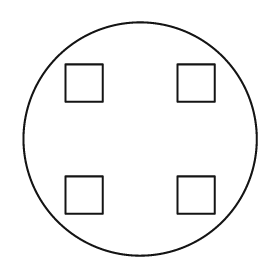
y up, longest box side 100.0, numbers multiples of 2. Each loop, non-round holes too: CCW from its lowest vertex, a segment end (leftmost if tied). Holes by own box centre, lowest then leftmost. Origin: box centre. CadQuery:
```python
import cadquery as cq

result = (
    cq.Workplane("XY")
    .moveTo(0.0, 0.0)
    .circle(50.0)
    .moveTo(-32.0, -32.0)
    .lineTo(-16.0, -32.0)
    .lineTo(-16.0, -16.0)
    .lineTo(-32.0, -16.0)
    .close()
    .moveTo(16.0, -32.0)
    .lineTo(32.0, -32.0)
    .lineTo(32.0, -16.0)
    .lineTo(16.0, -16.0)
    .close()
    .moveTo(-32.0, 16.0)
    .lineTo(-16.0, 16.0)
    .lineTo(-16.0, 32.0)
    .lineTo(-32.0, 32.0)
    .close()
    .moveTo(16.0, 16.0)
    .lineTo(32.0, 16.0)
    .lineTo(32.0, 32.0)
    .lineTo(16.0, 32.0)
    .close()
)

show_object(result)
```